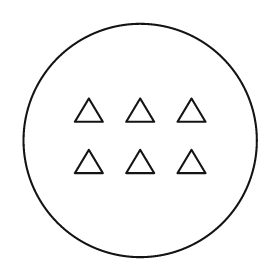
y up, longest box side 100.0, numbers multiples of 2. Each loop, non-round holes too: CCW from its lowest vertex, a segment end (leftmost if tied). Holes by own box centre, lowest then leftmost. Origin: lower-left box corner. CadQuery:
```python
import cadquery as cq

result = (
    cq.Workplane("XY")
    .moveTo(50.0, 50.0)
    .circle(50.0)
    .moveTo(22.0, 36.0)
    .lineTo(34.0, 36.0)
    .lineTo(28.0, 46.0)
    .close()
    .moveTo(44.0, 36.0)
    .lineTo(56.0, 36.0)
    .lineTo(50.0, 46.0)
    .close()
    .moveTo(66.0, 36.0)
    .lineTo(78.0, 36.0)
    .lineTo(72.0, 46.0)
    .close()
    .moveTo(22.0, 58.0)
    .lineTo(34.0, 58.0)
    .lineTo(28.0, 68.0)
    .close()
    .moveTo(44.0, 58.0)
    .lineTo(56.0, 58.0)
    .lineTo(50.0, 68.0)
    .close()
    .moveTo(66.0, 58.0)
    .lineTo(78.0, 58.0)
    .lineTo(72.0, 68.0)
    .close()
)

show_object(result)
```